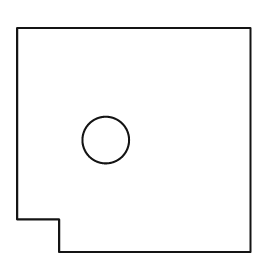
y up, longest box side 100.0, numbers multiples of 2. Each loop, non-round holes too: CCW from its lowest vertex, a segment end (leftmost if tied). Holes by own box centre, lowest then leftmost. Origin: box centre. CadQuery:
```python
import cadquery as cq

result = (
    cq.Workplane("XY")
    .moveTo(-32.0, -48.0)
    .lineTo(50.0, -48.0)
    .lineTo(50.0, 48.0)
    .lineTo(-50.0, 48.0)
    .lineTo(-50.0, -34.0)
    .lineTo(-32.0, -34.0)
    .close()
    .moveTo(-12.0, 0.0)
    .circle(10.0)
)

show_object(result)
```